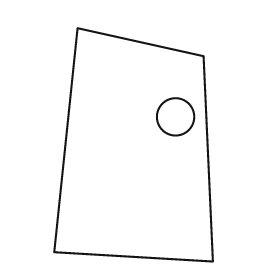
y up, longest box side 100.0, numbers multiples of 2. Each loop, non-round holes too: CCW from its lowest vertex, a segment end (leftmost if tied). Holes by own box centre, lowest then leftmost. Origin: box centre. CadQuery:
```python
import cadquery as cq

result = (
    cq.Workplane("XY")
    .moveTo(34.0, -50.0)
    .lineTo(30.0, 38.0)
    .lineTo(-24.0, 50.0)
    .lineTo(-34.0, -46.0)
    .close()
    .moveTo(18.0, 12.0)
    .circle(8.0)
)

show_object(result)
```